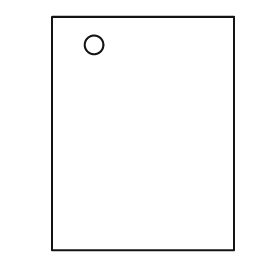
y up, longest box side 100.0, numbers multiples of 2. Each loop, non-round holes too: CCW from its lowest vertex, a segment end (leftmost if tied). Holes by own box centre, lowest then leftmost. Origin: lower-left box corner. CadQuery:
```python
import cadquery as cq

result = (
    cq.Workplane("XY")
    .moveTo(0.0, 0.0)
    .lineTo(78.0, 0.0)
    .lineTo(78.0, 100.0)
    .lineTo(0.0, 100.0)
    .close()
    .moveTo(18.0, 88.0)
    .circle(4.0)
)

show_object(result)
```